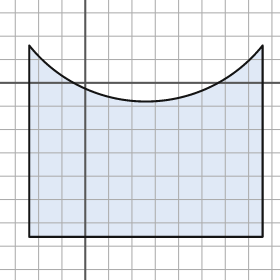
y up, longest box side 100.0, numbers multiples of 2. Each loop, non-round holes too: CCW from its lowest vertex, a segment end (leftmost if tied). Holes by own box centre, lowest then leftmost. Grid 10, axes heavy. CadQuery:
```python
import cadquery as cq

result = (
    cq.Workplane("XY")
    .moveTo(-24.0, -66.0)
    .lineTo(76.0, -66.0)
    .lineTo(76.0, 16.0)
    .threePointArc((26.0, -8.0), (-24.0, 16.0))
    .close()
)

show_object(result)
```